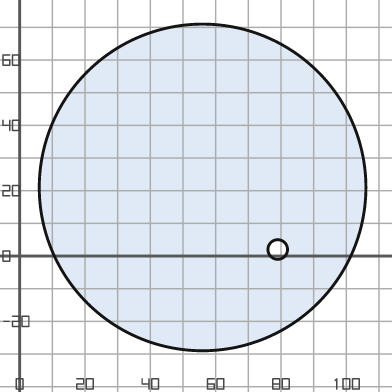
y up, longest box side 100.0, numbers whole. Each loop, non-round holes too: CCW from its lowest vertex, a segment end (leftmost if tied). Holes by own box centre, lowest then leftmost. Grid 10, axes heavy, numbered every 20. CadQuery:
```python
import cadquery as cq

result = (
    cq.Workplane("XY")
    .moveTo(56.0, 21.0)
    .circle(50.0)
    .moveTo(79.0, 2.0)
    .circle(3.0)
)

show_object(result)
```